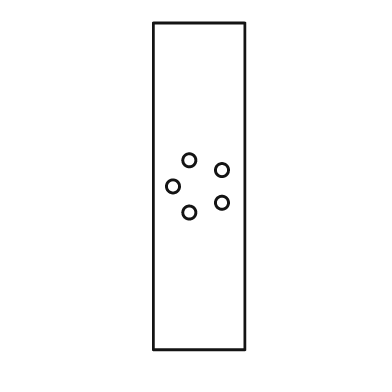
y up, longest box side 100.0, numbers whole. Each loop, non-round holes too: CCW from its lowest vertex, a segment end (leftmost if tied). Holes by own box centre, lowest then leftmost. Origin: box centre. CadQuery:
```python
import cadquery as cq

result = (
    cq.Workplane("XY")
    .moveTo(-14.0, -50.0)
    .lineTo(14.0, -50.0)
    .lineTo(14.0, 50.0)
    .lineTo(-14.0, 50.0)
    .close()
    .moveTo(-3.0, -8.0)
    .circle(2.0)
    .moveTo(7.0, -5.0)
    .circle(2.0)
    .moveTo(-8.0, 0.0)
    .circle(2.0)
    .moveTo(7.0, 5.0)
    .circle(2.0)
    .moveTo(-3.0, 8.0)
    .circle(2.0)
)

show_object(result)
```